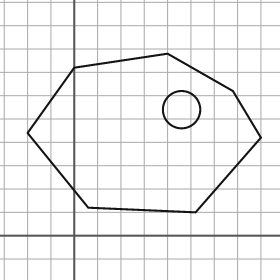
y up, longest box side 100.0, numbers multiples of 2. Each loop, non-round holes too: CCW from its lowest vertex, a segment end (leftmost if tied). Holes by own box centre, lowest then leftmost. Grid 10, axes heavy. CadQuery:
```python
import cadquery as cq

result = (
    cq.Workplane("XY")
    .moveTo(52.0, 10.0)
    .lineTo(80.0, 42.0)
    .lineTo(68.0, 62.0)
    .lineTo(40.0, 78.0)
    .lineTo(0.0, 72.0)
    .lineTo(-20.0, 44.0)
    .lineTo(6.0, 12.0)
    .close()
    .moveTo(46.0, 54.0)
    .circle(8.0)
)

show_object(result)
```